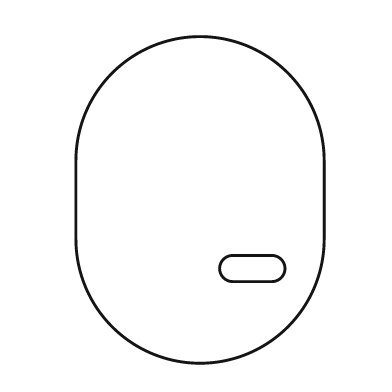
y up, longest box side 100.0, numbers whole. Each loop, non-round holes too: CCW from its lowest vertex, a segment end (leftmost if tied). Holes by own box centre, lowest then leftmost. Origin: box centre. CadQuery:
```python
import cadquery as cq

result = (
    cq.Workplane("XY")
    .moveTo(-38.0, -12.0)
    .threePointArc((0.0, -50.0), (38.0, -12.0))
    .lineTo(38.0, 12.0)
    .threePointArc((0.0, 50.0), (-38.0, 12.0))
    .close()
    .moveTo(10.0, -25.0)
    .lineTo(22.0, -25.0)
    .threePointArc((26.0, -21.0), (22.0, -17.0))
    .lineTo(10.0, -17.0)
    .threePointArc((6.0, -21.0), (10.0, -25.0))
    .close()
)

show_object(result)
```